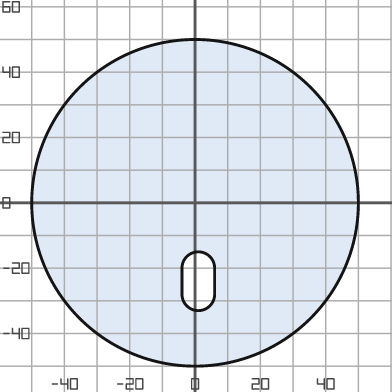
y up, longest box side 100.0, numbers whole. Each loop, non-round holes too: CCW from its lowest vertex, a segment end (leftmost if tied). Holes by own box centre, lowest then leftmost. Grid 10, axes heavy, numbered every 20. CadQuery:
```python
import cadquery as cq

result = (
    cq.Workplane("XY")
    .moveTo(0.0, 0.0)
    .circle(50.0)
    .moveTo(-4.0, -28.0)
    .threePointArc((1.0, -33.0), (6.0, -28.0))
    .lineTo(6.0, -20.0)
    .threePointArc((1.0, -15.0), (-4.0, -20.0))
    .close()
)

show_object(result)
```